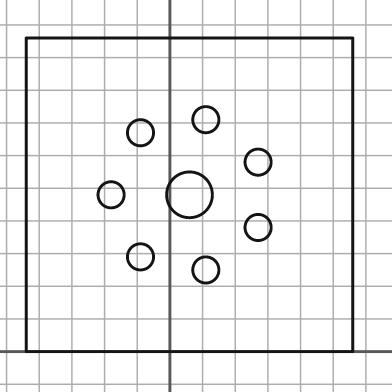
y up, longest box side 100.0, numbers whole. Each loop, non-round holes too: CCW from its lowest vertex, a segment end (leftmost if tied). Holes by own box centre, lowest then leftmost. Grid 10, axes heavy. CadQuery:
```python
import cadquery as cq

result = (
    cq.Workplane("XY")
    .moveTo(-44.0, 0.0)
    .lineTo(56.0, 0.0)
    .lineTo(56.0, 96.0)
    .lineTo(-44.0, 96.0)
    .close()
    .moveTo(11.0, 25.0)
    .circle(4.0)
    .moveTo(-9.0, 29.0)
    .circle(4.0)
    .moveTo(27.0, 38.0)
    .circle(4.0)
    .moveTo(-18.0, 48.0)
    .circle(4.0)
    .moveTo(6.0, 48.0)
    .circle(7.0)
    .moveTo(27.0, 58.0)
    .circle(4.0)
    .moveTo(-9.0, 67.0)
    .circle(4.0)
    .moveTo(11.0, 71.0)
    .circle(4.0)
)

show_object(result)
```